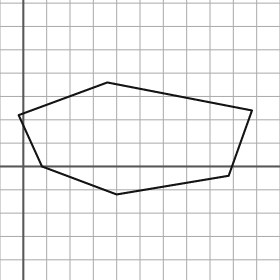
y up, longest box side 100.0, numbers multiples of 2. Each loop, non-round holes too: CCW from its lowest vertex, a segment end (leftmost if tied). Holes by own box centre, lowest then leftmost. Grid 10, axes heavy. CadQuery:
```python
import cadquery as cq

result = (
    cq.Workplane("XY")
    .moveTo(40.0, -12.0)
    .lineTo(88.0, -4.0)
    .lineTo(98.0, 24.0)
    .lineTo(36.0, 36.0)
    .lineTo(-2.0, 22.0)
    .lineTo(8.0, 0.0)
    .close()
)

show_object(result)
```